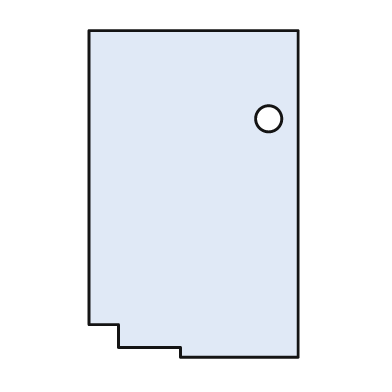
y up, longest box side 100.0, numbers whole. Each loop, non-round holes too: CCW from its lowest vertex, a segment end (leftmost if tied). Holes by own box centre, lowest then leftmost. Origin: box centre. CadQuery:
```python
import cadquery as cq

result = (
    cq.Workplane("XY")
    .moveTo(-4.0, -50.0)
    .lineTo(32.0, -50.0)
    .lineTo(32.0, 50.0)
    .lineTo(-32.0, 50.0)
    .lineTo(-32.0, -40.0)
    .lineTo(-23.0, -40.0)
    .lineTo(-23.0, -47.0)
    .lineTo(-4.0, -47.0)
    .close()
    .moveTo(23.0, 23.0)
    .circle(4.0)
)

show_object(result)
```